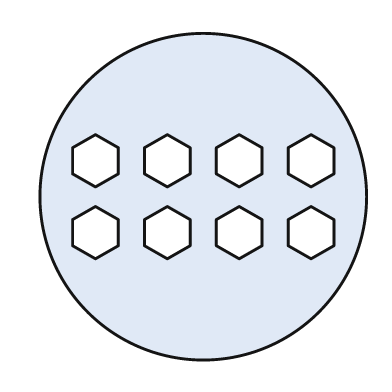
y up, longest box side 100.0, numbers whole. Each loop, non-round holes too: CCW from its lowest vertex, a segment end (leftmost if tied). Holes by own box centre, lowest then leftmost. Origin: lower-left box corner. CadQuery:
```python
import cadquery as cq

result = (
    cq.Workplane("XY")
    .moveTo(50.0, 50.0)
    .circle(50.0)
    .moveTo(17.0, 31.0)
    .lineTo(24.0, 35.0)
    .lineTo(24.0, 43.0)
    .lineTo(17.0, 47.0)
    .lineTo(10.0, 43.0)
    .lineTo(10.0, 35.0)
    .close()
    .moveTo(39.0, 31.0)
    .lineTo(46.0, 35.0)
    .lineTo(46.0, 43.0)
    .lineTo(39.0, 47.0)
    .lineTo(32.0, 43.0)
    .lineTo(32.0, 35.0)
    .close()
    .moveTo(61.0, 31.0)
    .lineTo(68.0, 35.0)
    .lineTo(68.0, 43.0)
    .lineTo(61.0, 47.0)
    .lineTo(54.0, 43.0)
    .lineTo(54.0, 35.0)
    .close()
    .moveTo(83.0, 31.0)
    .lineTo(90.0, 35.0)
    .lineTo(90.0, 43.0)
    .lineTo(83.0, 47.0)
    .lineTo(76.0, 43.0)
    .lineTo(76.0, 35.0)
    .close()
    .moveTo(17.0, 53.0)
    .lineTo(24.0, 57.0)
    .lineTo(24.0, 65.0)
    .lineTo(17.0, 69.0)
    .lineTo(10.0, 65.0)
    .lineTo(10.0, 57.0)
    .close()
    .moveTo(39.0, 53.0)
    .lineTo(46.0, 57.0)
    .lineTo(46.0, 65.0)
    .lineTo(39.0, 69.0)
    .lineTo(32.0, 65.0)
    .lineTo(32.0, 57.0)
    .close()
    .moveTo(61.0, 53.0)
    .lineTo(68.0, 57.0)
    .lineTo(68.0, 65.0)
    .lineTo(61.0, 69.0)
    .lineTo(54.0, 65.0)
    .lineTo(54.0, 57.0)
    .close()
    .moveTo(83.0, 53.0)
    .lineTo(90.0, 57.0)
    .lineTo(90.0, 65.0)
    .lineTo(83.0, 69.0)
    .lineTo(76.0, 65.0)
    .lineTo(76.0, 57.0)
    .close()
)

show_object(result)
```